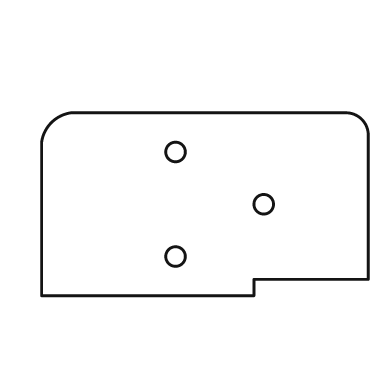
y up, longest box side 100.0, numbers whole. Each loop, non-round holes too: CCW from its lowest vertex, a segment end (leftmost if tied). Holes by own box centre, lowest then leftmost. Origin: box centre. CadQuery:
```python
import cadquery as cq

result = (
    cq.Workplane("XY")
    .moveTo(-50.0, -28.0)
    .lineTo(15.0, -28.0)
    .lineTo(15.0, -23.0)
    .lineTo(50.0, -23.0)
    .lineTo(50.0, 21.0)
    .threePointArc((48.0, 26.0), (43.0, 28.0))
    .lineTo(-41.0, 28.0)
    .threePointArc((-47.0, 25.0), (-50.0, 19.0))
    .close()
    .moveTo(-9.0, -16.0)
    .circle(3.0)
    .moveTo(18.0, 0.0)
    .circle(3.0)
    .moveTo(-9.0, 16.0)
    .circle(3.0)
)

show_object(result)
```